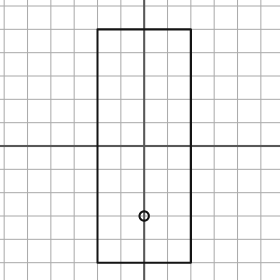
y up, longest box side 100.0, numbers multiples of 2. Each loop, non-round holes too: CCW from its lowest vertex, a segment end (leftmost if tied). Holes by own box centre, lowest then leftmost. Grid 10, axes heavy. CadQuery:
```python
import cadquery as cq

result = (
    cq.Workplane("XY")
    .moveTo(-20.0, -50.0)
    .lineTo(20.0, -50.0)
    .lineTo(20.0, 50.0)
    .lineTo(-20.0, 50.0)
    .close()
    .moveTo(0.0, -30.0)
    .circle(2.0)
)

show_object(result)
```